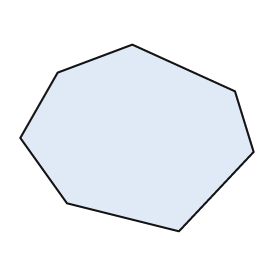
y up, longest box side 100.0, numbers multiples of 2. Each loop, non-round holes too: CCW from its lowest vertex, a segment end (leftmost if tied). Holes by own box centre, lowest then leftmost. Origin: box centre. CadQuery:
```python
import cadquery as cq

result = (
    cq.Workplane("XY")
    .moveTo(18.0, -40.0)
    .lineTo(50.0, -6.0)
    .lineTo(42.0, 20.0)
    .lineTo(-2.0, 40.0)
    .lineTo(-34.0, 28.0)
    .lineTo(-50.0, 0.0)
    .lineTo(-30.0, -28.0)
    .close()
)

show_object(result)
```